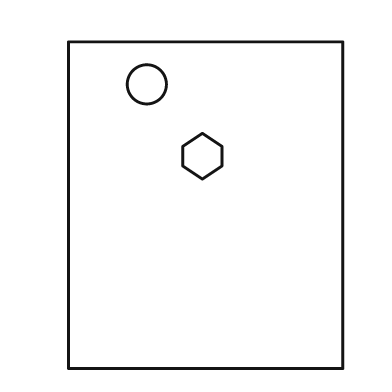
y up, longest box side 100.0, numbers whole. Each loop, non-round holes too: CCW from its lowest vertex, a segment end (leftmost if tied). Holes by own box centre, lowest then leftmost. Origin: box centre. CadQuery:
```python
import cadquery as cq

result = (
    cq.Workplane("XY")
    .moveTo(-42.0, -50.0)
    .lineTo(42.0, -50.0)
    .lineTo(42.0, 50.0)
    .lineTo(-42.0, 50.0)
    .close()
    .moveTo(-1.0, 8.0)
    .lineTo(5.0, 12.0)
    .lineTo(5.0, 18.0)
    .lineTo(-1.0, 22.0)
    .lineTo(-7.0, 18.0)
    .lineTo(-7.0, 12.0)
    .close()
    .moveTo(-18.0, 37.0)
    .circle(6.0)
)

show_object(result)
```